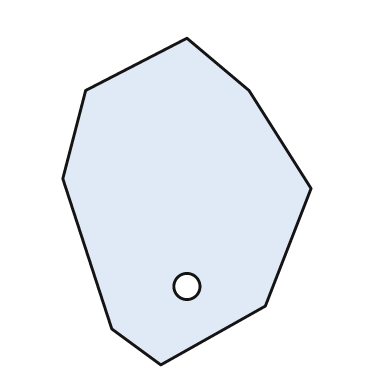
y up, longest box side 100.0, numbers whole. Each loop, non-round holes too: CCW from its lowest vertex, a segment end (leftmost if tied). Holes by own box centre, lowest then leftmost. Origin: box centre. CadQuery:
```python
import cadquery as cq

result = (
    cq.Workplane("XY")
    .moveTo(-8.0, -50.0)
    .lineTo(24.0, -32.0)
    .lineTo(38.0, 4.0)
    .lineTo(19.0, 34.0)
    .lineTo(0.0, 50.0)
    .lineTo(-31.0, 34.0)
    .lineTo(-38.0, 7.0)
    .lineTo(-23.0, -39.0)
    .close()
    .moveTo(0.0, -26.0)
    .circle(4.0)
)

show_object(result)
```